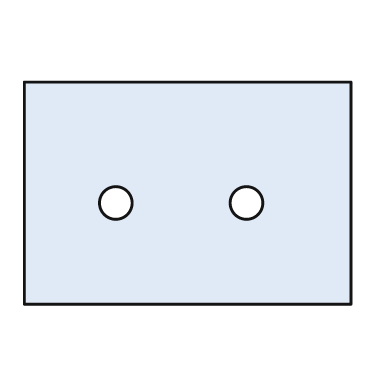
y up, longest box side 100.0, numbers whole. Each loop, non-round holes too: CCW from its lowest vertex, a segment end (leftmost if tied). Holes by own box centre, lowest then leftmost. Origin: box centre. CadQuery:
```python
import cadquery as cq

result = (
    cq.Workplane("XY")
    .moveTo(-50.0, -34.0)
    .lineTo(50.0, -34.0)
    .lineTo(50.0, 34.0)
    .lineTo(-50.0, 34.0)
    .close()
    .moveTo(-22.0, -3.0)
    .circle(5.0)
    .moveTo(18.0, -3.0)
    .circle(5.0)
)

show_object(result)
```